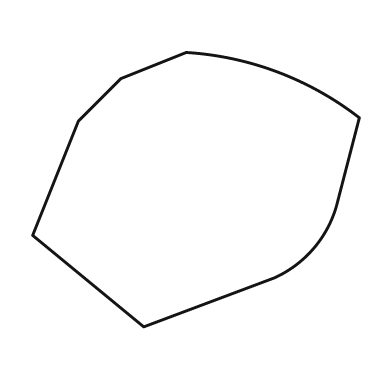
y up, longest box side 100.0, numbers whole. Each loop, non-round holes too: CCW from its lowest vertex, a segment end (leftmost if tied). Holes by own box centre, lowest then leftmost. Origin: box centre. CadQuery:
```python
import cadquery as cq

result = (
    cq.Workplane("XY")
    .moveTo(-16.0, -42.0)
    .lineTo(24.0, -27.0)
    .threePointArc((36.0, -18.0), (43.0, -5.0))
    .lineTo(50.0, 22.0)
    .threePointArc((25.0, 36.0), (-3.0, 42.0))
    .lineTo(-23.0, 34.0)
    .lineTo(-36.0, 21.0)
    .lineTo(-50.0, -14.0)
    .close()
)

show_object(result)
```